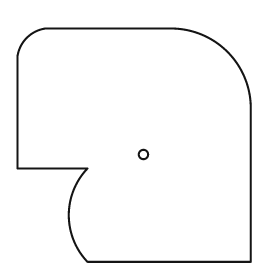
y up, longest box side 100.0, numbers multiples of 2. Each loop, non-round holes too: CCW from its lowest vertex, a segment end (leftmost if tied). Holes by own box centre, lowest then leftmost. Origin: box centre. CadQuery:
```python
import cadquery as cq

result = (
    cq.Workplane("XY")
    .moveTo(-20.0, -50.0)
    .lineTo(50.0, -50.0)
    .lineTo(50.0, 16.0)
    .threePointArc((40.0, 40.0), (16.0, 50.0))
    .lineTo(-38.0, 50.0)
    .threePointArc((-46.0, 46.0), (-50.0, 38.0))
    .lineTo(-50.0, -10.0)
    .lineTo(-20.0, -10.0)
    .threePointArc((-28.0, -30.0), (-20.0, -50.0))
    .close()
    .moveTo(4.0, -4.0)
    .circle(2.0)
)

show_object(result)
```